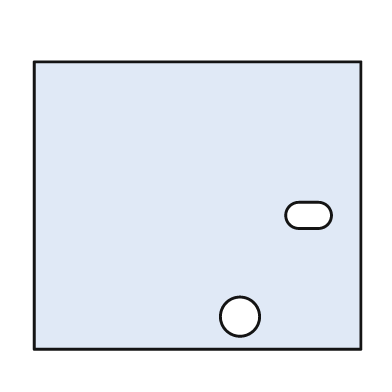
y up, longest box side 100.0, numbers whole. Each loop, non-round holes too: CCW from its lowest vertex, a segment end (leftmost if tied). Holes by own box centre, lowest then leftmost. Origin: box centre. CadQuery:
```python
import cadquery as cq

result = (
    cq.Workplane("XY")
    .moveTo(-50.0, -44.0)
    .lineTo(50.0, -44.0)
    .lineTo(50.0, 44.0)
    .lineTo(-50.0, 44.0)
    .close()
    .moveTo(13.0, -34.0)
    .circle(6.0)
    .moveTo(31.0, -7.0)
    .lineTo(37.0, -7.0)
    .threePointArc((41.0, -3.0), (37.0, 1.0))
    .lineTo(31.0, 1.0)
    .threePointArc((27.0, -3.0), (31.0, -7.0))
    .close()
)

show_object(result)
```